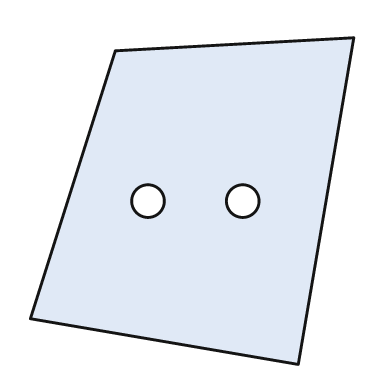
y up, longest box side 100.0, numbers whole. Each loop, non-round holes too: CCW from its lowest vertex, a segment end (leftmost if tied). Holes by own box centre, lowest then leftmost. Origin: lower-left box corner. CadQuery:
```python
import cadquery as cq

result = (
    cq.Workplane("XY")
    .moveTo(82.0, 0.0)
    .lineTo(99.0, 100.0)
    .lineTo(26.0, 96.0)
    .lineTo(0.0, 14.0)
    .close()
    .moveTo(36.0, 50.0)
    .circle(5.0)
    .moveTo(65.0, 50.0)
    .circle(5.0)
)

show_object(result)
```